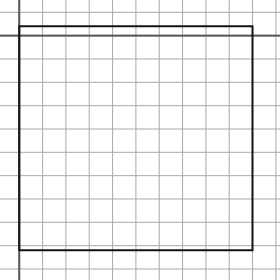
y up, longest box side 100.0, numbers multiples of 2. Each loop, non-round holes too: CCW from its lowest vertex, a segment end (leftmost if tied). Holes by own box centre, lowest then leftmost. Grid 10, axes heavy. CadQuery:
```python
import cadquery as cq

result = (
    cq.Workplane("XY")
    .moveTo(0.0, -92.0)
    .lineTo(100.0, -92.0)
    .lineTo(100.0, 4.0)
    .lineTo(0.0, 4.0)
    .close()
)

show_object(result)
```